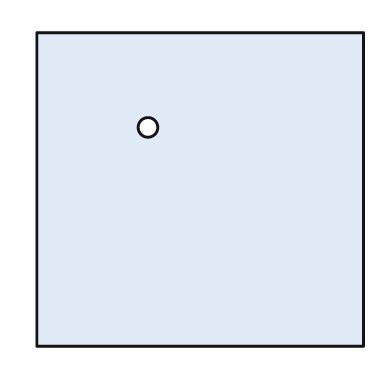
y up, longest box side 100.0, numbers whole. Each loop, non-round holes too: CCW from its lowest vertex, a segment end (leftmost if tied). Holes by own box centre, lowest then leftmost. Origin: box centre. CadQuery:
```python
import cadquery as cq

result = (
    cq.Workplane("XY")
    .moveTo(-50.0, -48.0)
    .lineTo(50.0, -48.0)
    .lineTo(50.0, 48.0)
    .lineTo(-50.0, 48.0)
    .close()
    .moveTo(-16.0, 19.0)
    .circle(3.0)
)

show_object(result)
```